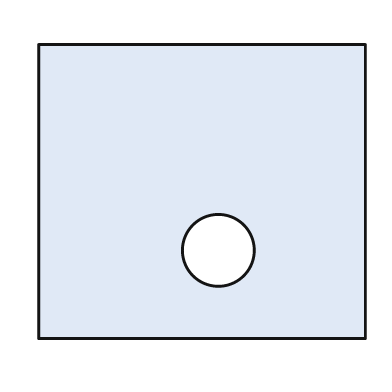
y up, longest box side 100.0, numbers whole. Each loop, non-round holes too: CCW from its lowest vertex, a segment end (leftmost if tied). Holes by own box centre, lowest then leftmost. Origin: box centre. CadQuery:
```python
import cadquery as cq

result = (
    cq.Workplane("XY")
    .moveTo(-50.0, -45.0)
    .lineTo(50.0, -45.0)
    .lineTo(50.0, 45.0)
    .lineTo(-50.0, 45.0)
    .close()
    .moveTo(5.0, -18.0)
    .circle(11.0)
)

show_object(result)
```